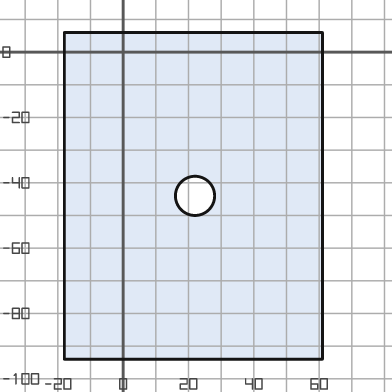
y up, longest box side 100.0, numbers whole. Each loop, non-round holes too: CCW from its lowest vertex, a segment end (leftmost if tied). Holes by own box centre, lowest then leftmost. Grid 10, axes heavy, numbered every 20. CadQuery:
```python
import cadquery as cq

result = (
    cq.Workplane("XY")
    .moveTo(-18.0, -94.0)
    .lineTo(61.0, -94.0)
    .lineTo(61.0, 6.0)
    .lineTo(-18.0, 6.0)
    .close()
    .moveTo(22.0, -44.0)
    .circle(6.0)
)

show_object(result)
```